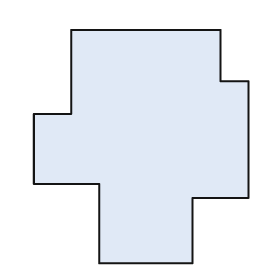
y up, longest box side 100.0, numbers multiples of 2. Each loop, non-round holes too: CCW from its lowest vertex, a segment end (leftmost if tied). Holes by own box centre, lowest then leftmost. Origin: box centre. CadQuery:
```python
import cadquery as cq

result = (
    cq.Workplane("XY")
    .moveTo(-18.0, -50.0)
    .lineTo(22.0, -50.0)
    .lineTo(22.0, -22.0)
    .lineTo(46.0, -22.0)
    .lineTo(46.0, 28.0)
    .lineTo(34.0, 28.0)
    .lineTo(34.0, 50.0)
    .lineTo(-30.0, 50.0)
    .lineTo(-30.0, 14.0)
    .lineTo(-46.0, 14.0)
    .lineTo(-46.0, -16.0)
    .lineTo(-18.0, -16.0)
    .close()
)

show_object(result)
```